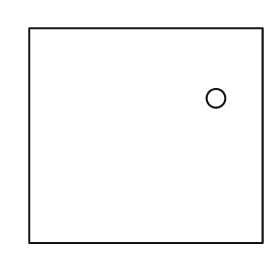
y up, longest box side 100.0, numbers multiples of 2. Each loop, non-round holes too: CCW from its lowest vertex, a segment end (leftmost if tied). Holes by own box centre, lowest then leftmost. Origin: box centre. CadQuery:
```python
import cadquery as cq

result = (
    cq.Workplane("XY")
    .moveTo(-50.0, -46.0)
    .lineTo(50.0, -46.0)
    .lineTo(50.0, 46.0)
    .lineTo(-50.0, 46.0)
    .close()
    .moveTo(30.0, 16.0)
    .circle(4.0)
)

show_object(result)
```